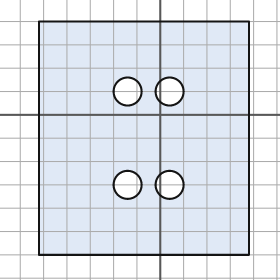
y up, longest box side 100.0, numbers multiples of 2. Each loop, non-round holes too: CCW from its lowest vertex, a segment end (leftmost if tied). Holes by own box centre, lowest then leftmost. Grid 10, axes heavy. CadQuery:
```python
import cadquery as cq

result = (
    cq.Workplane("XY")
    .moveTo(-52.0, -60.0)
    .lineTo(38.0, -60.0)
    .lineTo(38.0, 40.0)
    .lineTo(-52.0, 40.0)
    .close()
    .moveTo(-14.0, -30.0)
    .circle(6.0)
    .moveTo(4.0, -30.0)
    .circle(6.0)
    .moveTo(-14.0, 10.0)
    .circle(6.0)
    .moveTo(4.0, 10.0)
    .circle(6.0)
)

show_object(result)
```